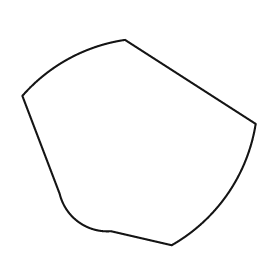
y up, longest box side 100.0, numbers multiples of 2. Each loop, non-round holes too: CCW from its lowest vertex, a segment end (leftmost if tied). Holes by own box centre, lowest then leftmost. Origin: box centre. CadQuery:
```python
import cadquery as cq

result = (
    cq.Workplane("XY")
    .moveTo(14.0, -44.0)
    .threePointArc((38.0, -22.0), (50.0, 8.0))
    .lineTo(-6.0, 44.0)
    .threePointArc((-30.0, 36.0), (-50.0, 20.0))
    .lineTo(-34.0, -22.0)
    .threePointArc((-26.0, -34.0), (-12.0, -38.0))
    .close()
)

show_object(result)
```